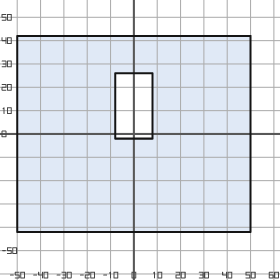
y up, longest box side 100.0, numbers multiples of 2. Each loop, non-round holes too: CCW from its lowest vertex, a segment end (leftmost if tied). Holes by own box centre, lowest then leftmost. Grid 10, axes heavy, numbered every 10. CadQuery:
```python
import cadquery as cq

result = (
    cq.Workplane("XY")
    .moveTo(-50.0, -42.0)
    .lineTo(50.0, -42.0)
    .lineTo(50.0, 42.0)
    .lineTo(-50.0, 42.0)
    .close()
    .moveTo(-8.0, -2.0)
    .lineTo(8.0, -2.0)
    .lineTo(8.0, 26.0)
    .lineTo(-8.0, 26.0)
    .close()
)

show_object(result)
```